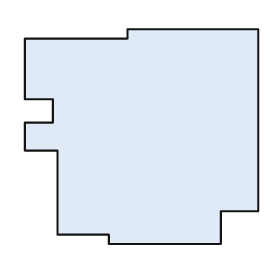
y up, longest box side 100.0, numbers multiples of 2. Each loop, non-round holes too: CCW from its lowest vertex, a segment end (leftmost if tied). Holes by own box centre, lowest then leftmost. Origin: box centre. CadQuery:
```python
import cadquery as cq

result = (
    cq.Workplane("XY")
    .moveTo(-14.0, -46.0)
    .lineTo(34.0, -46.0)
    .lineTo(34.0, -32.0)
    .lineTo(50.0, -32.0)
    .lineTo(50.0, 46.0)
    .lineTo(-6.0, 46.0)
    .lineTo(-6.0, 42.0)
    .lineTo(-50.0, 42.0)
    .lineTo(-50.0, 16.0)
    .lineTo(-38.0, 16.0)
    .lineTo(-38.0, 6.0)
    .lineTo(-50.0, 6.0)
    .lineTo(-50.0, -6.0)
    .lineTo(-36.0, -6.0)
    .lineTo(-36.0, -42.0)
    .lineTo(-14.0, -42.0)
    .close()
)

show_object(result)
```